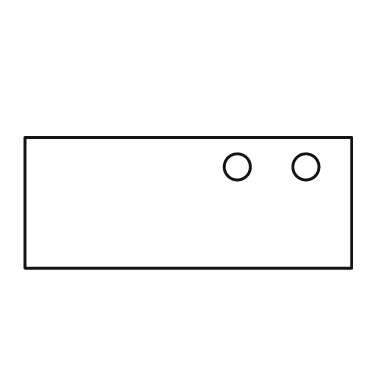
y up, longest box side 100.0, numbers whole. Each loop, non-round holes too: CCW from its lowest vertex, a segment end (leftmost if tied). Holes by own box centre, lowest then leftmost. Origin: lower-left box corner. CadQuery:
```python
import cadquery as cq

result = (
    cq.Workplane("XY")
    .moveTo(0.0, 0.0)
    .lineTo(100.0, 0.0)
    .lineTo(100.0, 40.0)
    .lineTo(0.0, 40.0)
    .close()
    .moveTo(65.0, 31.0)
    .circle(4.0)
    .moveTo(86.0, 31.0)
    .circle(4.0)
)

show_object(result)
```